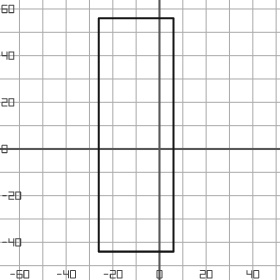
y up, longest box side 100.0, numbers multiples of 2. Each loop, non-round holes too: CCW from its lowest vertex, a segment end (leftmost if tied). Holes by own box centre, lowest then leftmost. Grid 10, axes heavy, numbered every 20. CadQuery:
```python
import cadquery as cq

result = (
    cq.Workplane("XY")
    .moveTo(-26.0, -44.0)
    .lineTo(6.0, -44.0)
    .lineTo(6.0, 56.0)
    .lineTo(-26.0, 56.0)
    .close()
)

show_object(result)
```